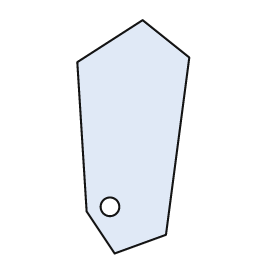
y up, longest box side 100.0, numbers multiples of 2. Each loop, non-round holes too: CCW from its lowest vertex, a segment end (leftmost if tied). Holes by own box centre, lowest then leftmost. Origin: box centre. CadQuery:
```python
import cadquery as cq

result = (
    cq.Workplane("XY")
    .moveTo(-8.0, -50.0)
    .lineTo(14.0, -42.0)
    .lineTo(24.0, 34.0)
    .lineTo(4.0, 50.0)
    .lineTo(-24.0, 32.0)
    .lineTo(-20.0, -32.0)
    .close()
    .moveTo(-10.0, -30.0)
    .circle(4.0)
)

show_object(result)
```